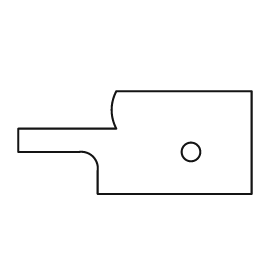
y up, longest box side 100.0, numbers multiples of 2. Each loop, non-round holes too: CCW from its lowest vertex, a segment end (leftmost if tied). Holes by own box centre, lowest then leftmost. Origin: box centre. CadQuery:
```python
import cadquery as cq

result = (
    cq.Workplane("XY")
    .moveTo(-16.0, -22.0)
    .lineTo(50.0, -22.0)
    .lineTo(50.0, 22.0)
    .lineTo(-8.0, 22.0)
    .threePointArc((-10.0, 14.0), (-8.0, 6.0))
    .lineTo(-50.0, 6.0)
    .lineTo(-50.0, -4.0)
    .lineTo(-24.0, -4.0)
    .threePointArc((-18.0, -6.0), (-16.0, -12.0))
    .close()
    .moveTo(24.0, -4.0)
    .circle(4.0)
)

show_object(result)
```